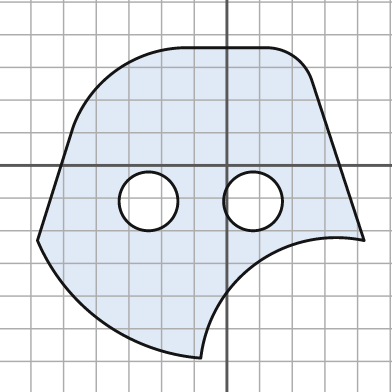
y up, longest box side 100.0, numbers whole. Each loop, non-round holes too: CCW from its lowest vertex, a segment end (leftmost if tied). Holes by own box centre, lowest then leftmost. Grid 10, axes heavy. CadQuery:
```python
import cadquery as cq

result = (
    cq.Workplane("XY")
    .moveTo(-8.0, -59.0)
    .threePointArc((9.0, -30.0), (42.0, -23.0))
    .lineTo(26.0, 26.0)
    .threePointArc((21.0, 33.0), (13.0, 36.0))
    .lineTo(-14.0, 36.0)
    .threePointArc((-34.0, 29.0), (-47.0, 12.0))
    .lineTo(-58.0, -23.0)
    .threePointArc((-38.0, -48.0), (-8.0, -59.0))
    .close()
    .moveTo(-24.0, -11.0)
    .circle(9.0)
    .moveTo(8.0, -11.0)
    .circle(9.0)
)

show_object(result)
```